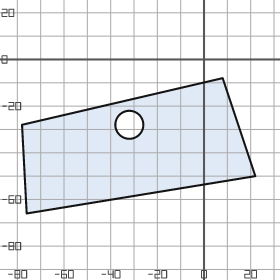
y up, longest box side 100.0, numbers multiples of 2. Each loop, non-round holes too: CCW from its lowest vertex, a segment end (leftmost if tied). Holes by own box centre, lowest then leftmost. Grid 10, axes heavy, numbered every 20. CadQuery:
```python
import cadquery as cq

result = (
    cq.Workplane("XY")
    .moveTo(-76.0, -66.0)
    .lineTo(22.0, -50.0)
    .lineTo(8.0, -8.0)
    .lineTo(-78.0, -28.0)
    .close()
    .moveTo(-32.0, -28.0)
    .circle(6.0)
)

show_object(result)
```